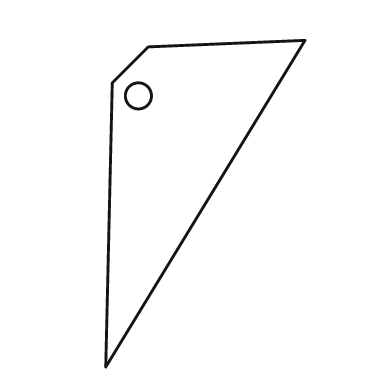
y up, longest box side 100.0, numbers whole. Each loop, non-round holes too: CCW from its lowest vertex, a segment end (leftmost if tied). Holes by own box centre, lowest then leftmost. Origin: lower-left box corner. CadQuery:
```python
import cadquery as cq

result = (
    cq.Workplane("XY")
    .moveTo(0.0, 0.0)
    .lineTo(61.0, 100.0)
    .lineTo(13.0, 98.0)
    .lineTo(2.0, 87.0)
    .close()
    .moveTo(10.0, 83.0)
    .circle(4.0)
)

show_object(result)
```